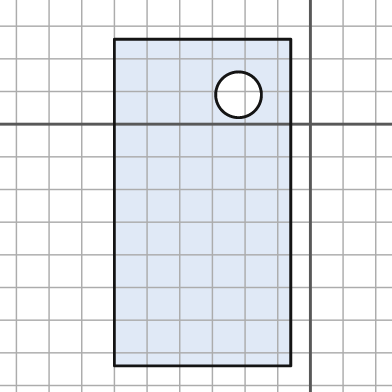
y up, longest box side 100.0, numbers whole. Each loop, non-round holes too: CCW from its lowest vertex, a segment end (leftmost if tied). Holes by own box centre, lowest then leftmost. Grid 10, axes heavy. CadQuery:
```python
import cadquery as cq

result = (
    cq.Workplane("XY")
    .moveTo(-60.0, -74.0)
    .lineTo(-6.0, -74.0)
    .lineTo(-6.0, 26.0)
    .lineTo(-60.0, 26.0)
    .close()
    .moveTo(-22.0, 9.0)
    .circle(7.0)
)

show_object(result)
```